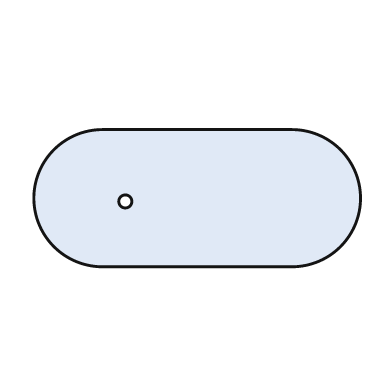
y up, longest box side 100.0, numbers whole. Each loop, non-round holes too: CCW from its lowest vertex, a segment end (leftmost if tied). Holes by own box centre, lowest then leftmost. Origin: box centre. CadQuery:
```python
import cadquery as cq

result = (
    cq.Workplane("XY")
    .moveTo(-29.0, -21.0)
    .lineTo(29.0, -21.0)
    .threePointArc((50.0, 0.0), (29.0, 21.0))
    .lineTo(-29.0, 21.0)
    .threePointArc((-50.0, 0.0), (-29.0, -21.0))
    .close()
    .moveTo(-22.0, -1.0)
    .circle(2.0)
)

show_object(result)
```